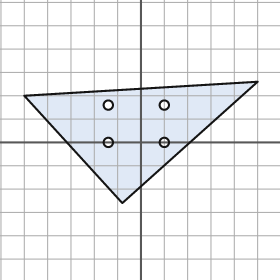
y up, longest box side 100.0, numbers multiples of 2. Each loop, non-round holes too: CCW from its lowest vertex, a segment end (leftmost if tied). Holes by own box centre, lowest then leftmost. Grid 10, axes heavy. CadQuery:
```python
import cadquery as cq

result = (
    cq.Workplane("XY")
    .moveTo(-8.0, -26.0)
    .lineTo(50.0, 26.0)
    .lineTo(-50.0, 20.0)
    .close()
    .moveTo(-14.0, 0.0)
    .circle(2.0)
    .moveTo(10.0, 0.0)
    .circle(2.0)
    .moveTo(-14.0, 16.0)
    .circle(2.0)
    .moveTo(10.0, 16.0)
    .circle(2.0)
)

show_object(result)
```